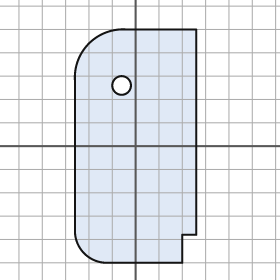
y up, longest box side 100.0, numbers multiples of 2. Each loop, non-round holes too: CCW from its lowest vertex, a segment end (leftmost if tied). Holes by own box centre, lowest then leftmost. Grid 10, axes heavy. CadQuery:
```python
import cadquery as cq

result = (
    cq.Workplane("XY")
    .moveTo(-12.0, -50.0)
    .lineTo(20.0, -50.0)
    .lineTo(20.0, -38.0)
    .lineTo(26.0, -38.0)
    .lineTo(26.0, 50.0)
    .lineTo(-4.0, 50.0)
    .threePointArc((-20.0, 44.0), (-26.0, 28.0))
    .lineTo(-26.0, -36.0)
    .threePointArc((-22.0, -46.0), (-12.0, -50.0))
    .close()
    .moveTo(-6.0, 26.0)
    .circle(4.0)
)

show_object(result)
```